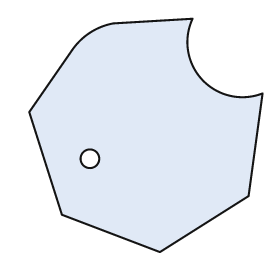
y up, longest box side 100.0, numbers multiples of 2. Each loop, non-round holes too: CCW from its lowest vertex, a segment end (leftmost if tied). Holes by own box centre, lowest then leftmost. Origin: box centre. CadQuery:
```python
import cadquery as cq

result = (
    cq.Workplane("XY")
    .moveTo(6.0, -50.0)
    .lineTo(44.0, -26.0)
    .lineTo(50.0, 18.0)
    .threePointArc((24.0, 24.0), (20.0, 50.0))
    .lineTo(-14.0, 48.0)
    .threePointArc((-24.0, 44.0), (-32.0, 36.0))
    .lineTo(-50.0, 10.0)
    .lineTo(-36.0, -34.0)
    .close()
    .moveTo(-24.0, -10.0)
    .circle(4.0)
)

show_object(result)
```